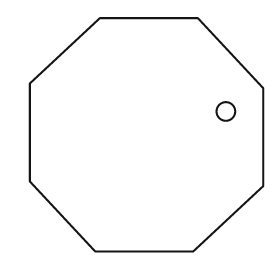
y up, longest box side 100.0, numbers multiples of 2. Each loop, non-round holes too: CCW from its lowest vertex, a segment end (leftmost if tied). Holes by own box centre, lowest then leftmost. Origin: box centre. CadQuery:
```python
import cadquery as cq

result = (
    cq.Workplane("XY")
    .moveTo(-22.0, -50.0)
    .lineTo(20.0, -50.0)
    .lineTo(50.0, -22.0)
    .lineTo(50.0, 20.0)
    .lineTo(22.0, 50.0)
    .lineTo(-20.0, 50.0)
    .lineTo(-50.0, 22.0)
    .lineTo(-50.0, -20.0)
    .close()
    .moveTo(34.0, 10.0)
    .circle(4.0)
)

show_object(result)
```